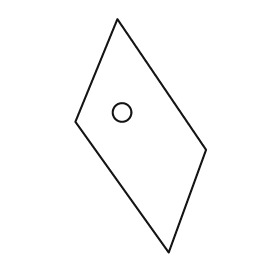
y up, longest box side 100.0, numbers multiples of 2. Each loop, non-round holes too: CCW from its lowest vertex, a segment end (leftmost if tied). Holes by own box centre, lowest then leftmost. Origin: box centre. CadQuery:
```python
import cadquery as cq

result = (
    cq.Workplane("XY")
    .moveTo(12.0, -50.0)
    .lineTo(28.0, -6.0)
    .lineTo(-10.0, 50.0)
    .lineTo(-28.0, 6.0)
    .close()
    .moveTo(-8.0, 10.0)
    .circle(4.0)
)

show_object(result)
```